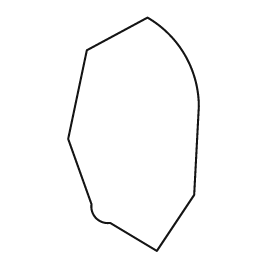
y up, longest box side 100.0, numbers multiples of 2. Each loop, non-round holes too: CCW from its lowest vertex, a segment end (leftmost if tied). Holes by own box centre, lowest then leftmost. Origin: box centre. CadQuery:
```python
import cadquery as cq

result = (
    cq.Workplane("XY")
    .moveTo(10.0, -50.0)
    .lineTo(26.0, -26.0)
    .lineTo(28.0, 12.0)
    .threePointArc((22.0, 34.0), (6.0, 50.0))
    .lineTo(-20.0, 36.0)
    .lineTo(-28.0, -2.0)
    .lineTo(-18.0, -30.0)
    .threePointArc((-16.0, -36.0), (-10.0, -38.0))
    .close()
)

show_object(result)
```